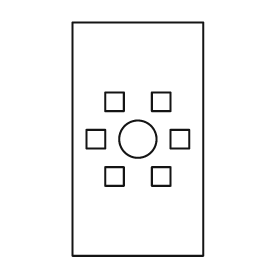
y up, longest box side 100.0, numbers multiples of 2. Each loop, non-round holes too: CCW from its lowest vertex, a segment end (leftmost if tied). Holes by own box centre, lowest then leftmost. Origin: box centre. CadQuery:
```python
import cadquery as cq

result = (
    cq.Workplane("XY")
    .moveTo(-28.0, -50.0)
    .lineTo(28.0, -50.0)
    .lineTo(28.0, 50.0)
    .lineTo(-28.0, 50.0)
    .close()
    .moveTo(-14.0, -20.0)
    .lineTo(-6.0, -20.0)
    .lineTo(-6.0, -12.0)
    .lineTo(-14.0, -12.0)
    .close()
    .moveTo(6.0, -20.0)
    .lineTo(14.0, -20.0)
    .lineTo(14.0, -12.0)
    .lineTo(6.0, -12.0)
    .close()
    .moveTo(-22.0, -4.0)
    .lineTo(-14.0, -4.0)
    .lineTo(-14.0, 4.0)
    .lineTo(-22.0, 4.0)
    .close()
    .moveTo(0.0, 0.0)
    .circle(8.0)
    .moveTo(14.0, -4.0)
    .lineTo(22.0, -4.0)
    .lineTo(22.0, 4.0)
    .lineTo(14.0, 4.0)
    .close()
    .moveTo(-14.0, 12.0)
    .lineTo(-6.0, 12.0)
    .lineTo(-6.0, 20.0)
    .lineTo(-14.0, 20.0)
    .close()
    .moveTo(6.0, 12.0)
    .lineTo(14.0, 12.0)
    .lineTo(14.0, 20.0)
    .lineTo(6.0, 20.0)
    .close()
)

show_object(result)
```